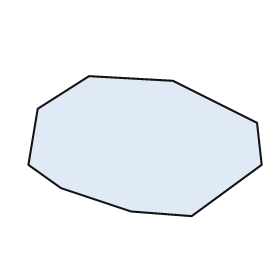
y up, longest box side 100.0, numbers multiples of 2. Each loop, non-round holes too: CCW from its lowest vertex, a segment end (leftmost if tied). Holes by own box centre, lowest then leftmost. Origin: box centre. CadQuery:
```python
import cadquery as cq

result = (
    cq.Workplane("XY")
    .moveTo(20.0, -30.0)
    .lineTo(50.0, -8.0)
    .lineTo(48.0, 10.0)
    .lineTo(12.0, 28.0)
    .lineTo(-24.0, 30.0)
    .lineTo(-46.0, 16.0)
    .lineTo(-50.0, -8.0)
    .lineTo(-36.0, -18.0)
    .lineTo(-6.0, -28.0)
    .close()
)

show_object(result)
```